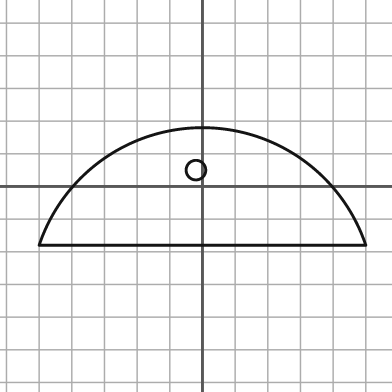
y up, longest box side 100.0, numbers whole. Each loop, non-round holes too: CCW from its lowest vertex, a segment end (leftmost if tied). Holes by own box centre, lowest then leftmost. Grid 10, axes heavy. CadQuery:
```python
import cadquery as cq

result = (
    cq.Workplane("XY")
    .moveTo(-50.0, -18.0)
    .lineTo(50.0, -18.0)
    .threePointArc((0.0, 18.0), (-50.0, -18.0))
    .close()
    .moveTo(-2.0, 5.0)
    .circle(3.0)
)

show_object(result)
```